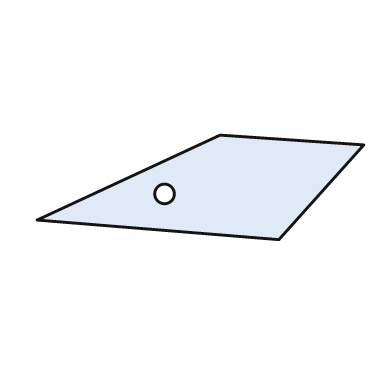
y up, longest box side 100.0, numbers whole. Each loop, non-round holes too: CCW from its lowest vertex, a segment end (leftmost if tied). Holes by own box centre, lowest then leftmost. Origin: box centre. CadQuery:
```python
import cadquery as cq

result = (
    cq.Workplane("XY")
    .moveTo(24.0, -16.0)
    .lineTo(50.0, 13.0)
    .lineTo(6.0, 16.0)
    .lineTo(-50.0, -10.0)
    .close()
    .moveTo(-11.0, -2.0)
    .circle(3.0)
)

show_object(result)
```